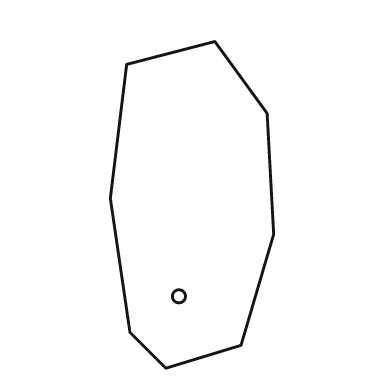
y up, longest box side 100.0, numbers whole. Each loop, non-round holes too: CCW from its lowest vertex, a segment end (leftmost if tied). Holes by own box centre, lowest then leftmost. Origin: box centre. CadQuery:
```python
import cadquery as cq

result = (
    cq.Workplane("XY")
    .moveTo(-8.0, -50.0)
    .lineTo(15.0, -43.0)
    .lineTo(25.0, -9.0)
    .lineTo(23.0, 28.0)
    .lineTo(7.0, 50.0)
    .lineTo(-20.0, 43.0)
    .lineTo(-25.0, 2.0)
    .lineTo(-19.0, -39.0)
    .close()
    .moveTo(-4.0, -28.0)
    .circle(2.0)
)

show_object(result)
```